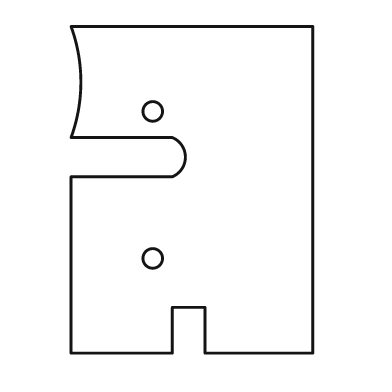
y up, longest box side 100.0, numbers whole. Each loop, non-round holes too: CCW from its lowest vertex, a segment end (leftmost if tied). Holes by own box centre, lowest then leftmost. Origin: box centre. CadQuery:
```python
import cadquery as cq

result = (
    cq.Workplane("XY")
    .moveTo(-37.0, -50.0)
    .lineTo(-6.0, -50.0)
    .lineTo(-6.0, -36.0)
    .lineTo(4.0, -36.0)
    .lineTo(4.0, -50.0)
    .lineTo(37.0, -50.0)
    .lineTo(37.0, 50.0)
    .lineTo(-37.0, 50.0)
    .threePointArc((-34.0, 33.0), (-37.0, 16.0))
    .lineTo(-6.0, 16.0)
    .threePointArc((-2.0, 10.0), (-6.0, 4.0))
    .lineTo(-37.0, 4.0)
    .close()
    .moveTo(-12.0, -21.0)
    .circle(3.0)
    .moveTo(-12.0, 24.0)
    .circle(3.0)
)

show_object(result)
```